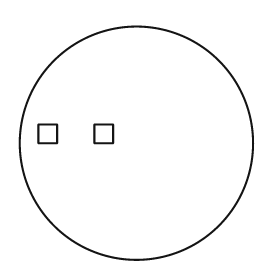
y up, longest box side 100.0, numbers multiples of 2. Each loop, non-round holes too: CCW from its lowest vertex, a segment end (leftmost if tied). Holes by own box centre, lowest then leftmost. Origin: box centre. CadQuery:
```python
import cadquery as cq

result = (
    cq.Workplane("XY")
    .moveTo(0.0, 0.0)
    .circle(50.0)
    .moveTo(-42.0, 0.0)
    .lineTo(-34.0, 0.0)
    .lineTo(-34.0, 8.0)
    .lineTo(-42.0, 8.0)
    .close()
    .moveTo(-18.0, 0.0)
    .lineTo(-10.0, 0.0)
    .lineTo(-10.0, 8.0)
    .lineTo(-18.0, 8.0)
    .close()
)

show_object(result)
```